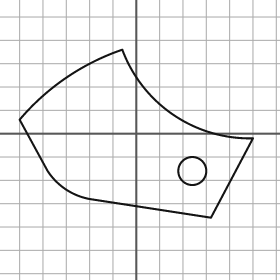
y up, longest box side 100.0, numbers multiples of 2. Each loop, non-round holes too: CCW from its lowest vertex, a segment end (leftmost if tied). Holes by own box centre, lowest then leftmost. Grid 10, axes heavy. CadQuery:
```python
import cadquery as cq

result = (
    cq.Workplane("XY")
    .moveTo(32.0, -36.0)
    .lineTo(50.0, -2.0)
    .threePointArc((16.0, 8.0), (-6.0, 36.0))
    .threePointArc((-30.0, 24.0), (-50.0, 6.0))
    .lineTo(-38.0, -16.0)
    .threePointArc((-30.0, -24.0), (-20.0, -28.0))
    .close()
    .moveTo(24.0, -16.0)
    .circle(6.0)
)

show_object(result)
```